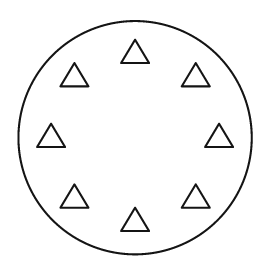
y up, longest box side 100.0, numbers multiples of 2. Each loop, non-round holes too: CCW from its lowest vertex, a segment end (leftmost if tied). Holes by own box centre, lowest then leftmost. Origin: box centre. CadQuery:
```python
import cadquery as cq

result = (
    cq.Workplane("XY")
    .moveTo(0.0, 0.0)
    .circle(50.0)
    .moveTo(-6.0, -40.0)
    .lineTo(6.0, -40.0)
    .lineTo(0.0, -30.0)
    .close()
    .moveTo(-32.0, -30.0)
    .lineTo(-20.0, -30.0)
    .lineTo(-26.0, -20.0)
    .close()
    .moveTo(20.0, -30.0)
    .lineTo(32.0, -30.0)
    .lineTo(26.0, -20.0)
    .close()
    .moveTo(-42.0, -4.0)
    .lineTo(-30.0, -4.0)
    .lineTo(-36.0, 6.0)
    .close()
    .moveTo(30.0, -4.0)
    .lineTo(42.0, -4.0)
    .lineTo(36.0, 6.0)
    .close()
    .moveTo(-32.0, 22.0)
    .lineTo(-20.0, 22.0)
    .lineTo(-26.0, 32.0)
    .close()
    .moveTo(20.0, 22.0)
    .lineTo(32.0, 22.0)
    .lineTo(26.0, 32.0)
    .close()
    .moveTo(-6.0, 32.0)
    .lineTo(6.0, 32.0)
    .lineTo(0.0, 42.0)
    .close()
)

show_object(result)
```